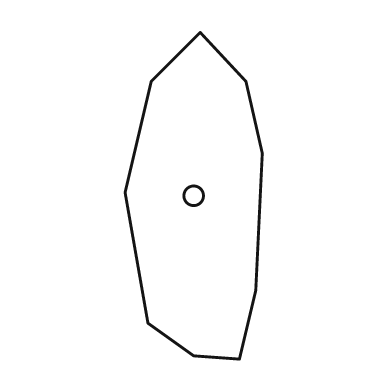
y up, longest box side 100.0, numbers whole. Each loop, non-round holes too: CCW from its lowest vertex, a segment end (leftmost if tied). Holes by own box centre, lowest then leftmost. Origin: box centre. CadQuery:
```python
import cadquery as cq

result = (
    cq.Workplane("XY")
    .moveTo(14.0, -50.0)
    .lineTo(19.0, -29.0)
    .lineTo(21.0, 13.0)
    .lineTo(16.0, 35.0)
    .lineTo(2.0, 50.0)
    .lineTo(-13.0, 35.0)
    .lineTo(-21.0, 1.0)
    .lineTo(-14.0, -39.0)
    .lineTo(0.0, -49.0)
    .close()
    .moveTo(0.0, 0.0)
    .circle(3.0)
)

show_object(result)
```